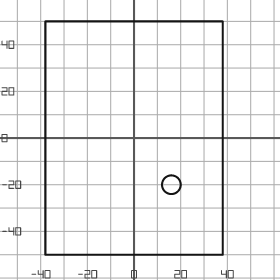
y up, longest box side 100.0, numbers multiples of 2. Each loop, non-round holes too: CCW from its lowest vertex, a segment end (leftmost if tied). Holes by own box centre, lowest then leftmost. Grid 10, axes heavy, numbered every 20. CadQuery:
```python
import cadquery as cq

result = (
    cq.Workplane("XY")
    .moveTo(-38.0, -50.0)
    .lineTo(38.0, -50.0)
    .lineTo(38.0, 50.0)
    .lineTo(-38.0, 50.0)
    .close()
    .moveTo(16.0, -20.0)
    .circle(4.0)
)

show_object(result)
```